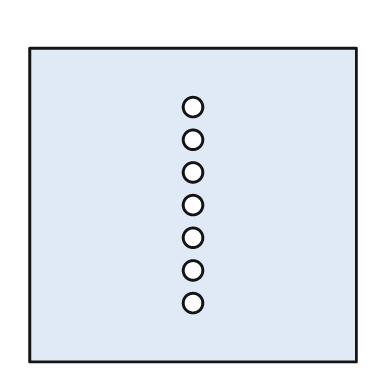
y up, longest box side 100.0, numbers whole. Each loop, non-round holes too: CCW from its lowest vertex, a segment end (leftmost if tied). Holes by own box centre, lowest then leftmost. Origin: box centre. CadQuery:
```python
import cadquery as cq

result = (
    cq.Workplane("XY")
    .moveTo(-50.0, -48.0)
    .lineTo(50.0, -48.0)
    .lineTo(50.0, 48.0)
    .lineTo(-50.0, 48.0)
    .close()
    .moveTo(0.0, -30.0)
    .circle(3.0)
    .moveTo(0.0, -20.0)
    .circle(3.0)
    .moveTo(0.0, -10.0)
    .circle(3.0)
    .moveTo(0.0, 0.0)
    .circle(3.0)
    .moveTo(0.0, 10.0)
    .circle(3.0)
    .moveTo(0.0, 20.0)
    .circle(3.0)
    .moveTo(0.0, 30.0)
    .circle(3.0)
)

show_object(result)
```